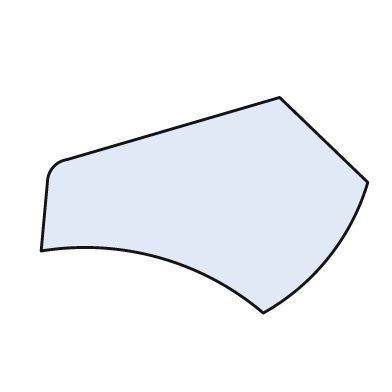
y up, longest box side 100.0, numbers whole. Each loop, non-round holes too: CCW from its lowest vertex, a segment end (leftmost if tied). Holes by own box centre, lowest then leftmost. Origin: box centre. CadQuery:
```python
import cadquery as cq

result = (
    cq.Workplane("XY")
    .moveTo(18.0, -33.0)
    .threePointArc((38.0, -16.0), (50.0, 7.0))
    .lineTo(23.0, 33.0)
    .lineTo(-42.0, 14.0)
    .threePointArc((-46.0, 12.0), (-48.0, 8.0))
    .lineTo(-50.0, -14.0)
    .threePointArc((-14.0, -16.0), (18.0, -33.0))
    .close()
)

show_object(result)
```